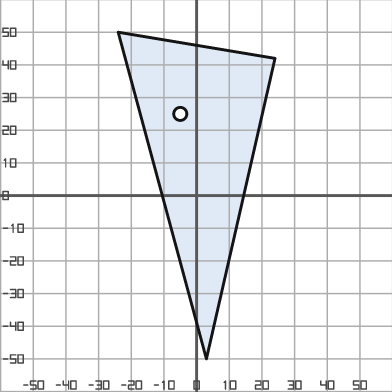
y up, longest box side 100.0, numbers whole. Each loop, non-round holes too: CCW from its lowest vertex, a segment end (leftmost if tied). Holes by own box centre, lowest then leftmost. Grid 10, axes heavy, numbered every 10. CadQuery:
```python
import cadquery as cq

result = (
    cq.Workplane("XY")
    .moveTo(3.0, -50.0)
    .lineTo(24.0, 42.0)
    .lineTo(-24.0, 50.0)
    .close()
    .moveTo(-5.0, 25.0)
    .circle(2.0)
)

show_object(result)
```